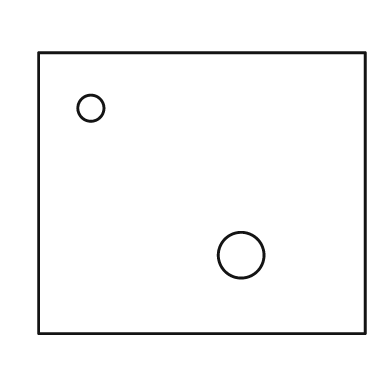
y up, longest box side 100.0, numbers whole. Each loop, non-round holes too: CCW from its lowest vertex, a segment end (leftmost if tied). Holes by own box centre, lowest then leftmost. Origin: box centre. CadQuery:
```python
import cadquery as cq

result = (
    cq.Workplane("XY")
    .moveTo(-50.0, -43.0)
    .lineTo(50.0, -43.0)
    .lineTo(50.0, 43.0)
    .lineTo(-50.0, 43.0)
    .close()
    .moveTo(12.0, -19.0)
    .circle(7.0)
    .moveTo(-34.0, 26.0)
    .circle(4.0)
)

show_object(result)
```